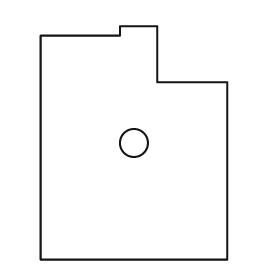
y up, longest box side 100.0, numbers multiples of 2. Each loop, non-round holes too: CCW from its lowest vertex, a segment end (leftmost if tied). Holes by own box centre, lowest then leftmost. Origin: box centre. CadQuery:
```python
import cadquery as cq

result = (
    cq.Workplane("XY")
    .moveTo(-40.0, -50.0)
    .lineTo(40.0, -50.0)
    .lineTo(40.0, 26.0)
    .lineTo(10.0, 26.0)
    .lineTo(10.0, 50.0)
    .lineTo(-6.0, 50.0)
    .lineTo(-6.0, 46.0)
    .lineTo(-40.0, 46.0)
    .close()
    .moveTo(0.0, 0.0)
    .circle(6.0)
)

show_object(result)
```